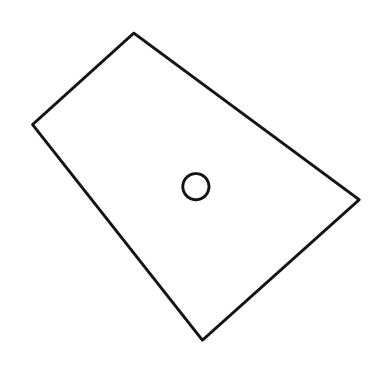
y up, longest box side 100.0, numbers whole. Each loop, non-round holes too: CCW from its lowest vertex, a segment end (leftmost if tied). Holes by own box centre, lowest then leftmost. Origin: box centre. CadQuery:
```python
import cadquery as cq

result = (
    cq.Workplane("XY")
    .moveTo(2.0, -47.0)
    .lineTo(50.0, -4.0)
    .lineTo(-19.0, 47.0)
    .lineTo(-50.0, 19.0)
    .close()
    .moveTo(0.0, 0.0)
    .circle(4.0)
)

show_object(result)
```